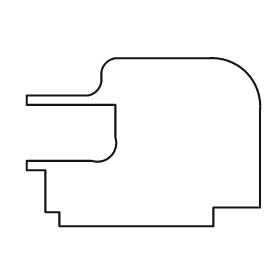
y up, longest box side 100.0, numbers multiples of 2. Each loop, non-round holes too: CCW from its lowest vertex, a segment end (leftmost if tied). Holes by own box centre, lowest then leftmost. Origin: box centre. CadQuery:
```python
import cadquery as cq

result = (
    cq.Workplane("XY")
    .moveTo(-36.0, -36.0)
    .lineTo(30.0, -36.0)
    .lineTo(30.0, -28.0)
    .lineTo(50.0, -28.0)
    .lineTo(50.0, 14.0)
    .threePointArc((44.0, 30.0), (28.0, 36.0))
    .lineTo(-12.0, 36.0)
    .threePointArc((-16.0, 34.0), (-18.0, 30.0))
    .lineTo(-18.0, 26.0)
    .threePointArc((-20.0, 22.0), (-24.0, 20.0))
    .lineTo(-50.0, 20.0)
    .lineTo(-50.0, 16.0)
    .lineTo(-12.0, 16.0)
    .lineTo(-12.0, 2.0)
    .threePointArc((-14.0, -6.0), (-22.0, -8.0))
    .lineTo(-50.0, -8.0)
    .lineTo(-50.0, -12.0)
    .lineTo(-42.0, -12.0)
    .lineTo(-42.0, -30.0)
    .lineTo(-36.0, -30.0)
    .close()
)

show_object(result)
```